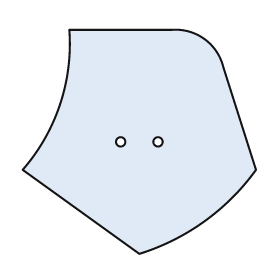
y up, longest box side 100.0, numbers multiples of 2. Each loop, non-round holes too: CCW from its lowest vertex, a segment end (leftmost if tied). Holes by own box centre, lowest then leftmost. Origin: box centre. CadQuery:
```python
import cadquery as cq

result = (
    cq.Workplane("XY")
    .moveTo(0.0, -48.0)
    .threePointArc((28.0, -34.0), (50.0, -12.0))
    .lineTo(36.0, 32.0)
    .threePointArc((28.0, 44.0), (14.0, 48.0))
    .lineTo(-30.0, 48.0)
    .threePointArc((-34.0, 16.0), (-50.0, -12.0))
    .close()
    .moveTo(-8.0, 0.0)
    .circle(2.0)
    .moveTo(8.0, 0.0)
    .circle(2.0)
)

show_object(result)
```